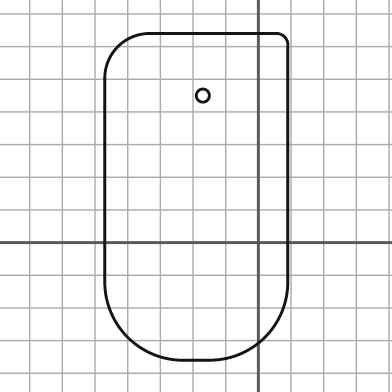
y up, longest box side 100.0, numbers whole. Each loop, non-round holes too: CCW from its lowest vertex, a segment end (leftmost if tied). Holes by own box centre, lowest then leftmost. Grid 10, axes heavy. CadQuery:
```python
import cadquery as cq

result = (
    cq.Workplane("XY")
    .moveTo(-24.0, -36.0)
    .lineTo(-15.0, -36.0)
    .threePointArc((2.0, -29.0), (9.0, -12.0))
    .lineTo(9.0, 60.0)
    .threePointArc((8.0, 63.0), (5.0, 64.0))
    .lineTo(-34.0, 64.0)
    .threePointArc((-43.0, 60.0), (-47.0, 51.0))
    .lineTo(-47.0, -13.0)
    .threePointArc((-40.0, -29.0), (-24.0, -36.0))
    .close()
    .moveTo(-17.0, 45.0)
    .circle(2.0)
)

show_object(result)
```